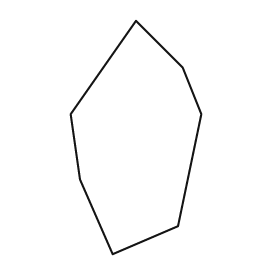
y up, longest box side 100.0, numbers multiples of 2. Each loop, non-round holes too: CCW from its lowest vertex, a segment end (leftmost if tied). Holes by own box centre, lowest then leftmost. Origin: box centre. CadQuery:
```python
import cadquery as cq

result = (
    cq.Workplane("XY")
    .moveTo(-10.0, -50.0)
    .lineTo(18.0, -38.0)
    .lineTo(28.0, 10.0)
    .lineTo(20.0, 30.0)
    .lineTo(0.0, 50.0)
    .lineTo(-28.0, 10.0)
    .lineTo(-24.0, -18.0)
    .close()
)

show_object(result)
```